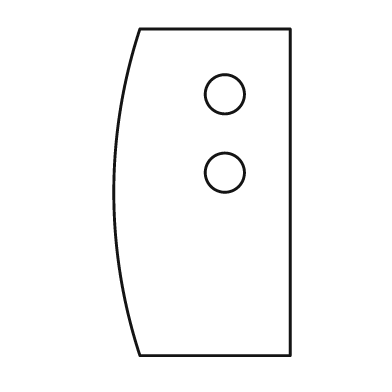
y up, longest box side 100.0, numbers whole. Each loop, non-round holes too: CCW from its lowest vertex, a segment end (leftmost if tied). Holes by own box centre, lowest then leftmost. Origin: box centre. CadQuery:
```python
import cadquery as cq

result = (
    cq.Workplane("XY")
    .moveTo(-19.0, -50.0)
    .lineTo(27.0, -50.0)
    .lineTo(27.0, 50.0)
    .lineTo(-19.0, 50.0)
    .threePointArc((-27.0, 0.0), (-19.0, -50.0))
    .close()
    .moveTo(7.0, 6.0)
    .circle(6.0)
    .moveTo(7.0, 30.0)
    .circle(6.0)
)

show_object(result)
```